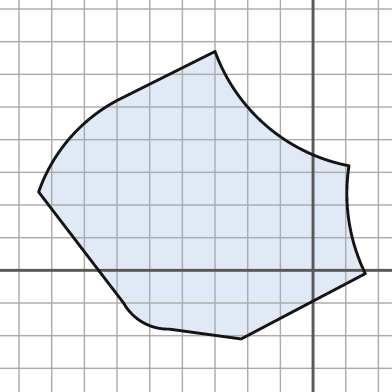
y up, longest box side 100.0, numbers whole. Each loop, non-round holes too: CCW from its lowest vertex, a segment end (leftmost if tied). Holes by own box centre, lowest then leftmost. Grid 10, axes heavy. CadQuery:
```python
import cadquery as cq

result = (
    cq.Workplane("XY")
    .moveTo(-22.0, -21.0)
    .lineTo(16.0, -1.0)
    .threePointArc((11.0, 15.0), (11.0, 32.0))
    .threePointArc((-14.0, 44.0), (-30.0, 67.0))
    .lineTo(-58.0, 53.0)
    .threePointArc((-74.0, 41.0), (-84.0, 24.0))
    .lineTo(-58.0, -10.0)
    .threePointArc((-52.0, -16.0), (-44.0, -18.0))
    .close()
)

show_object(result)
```